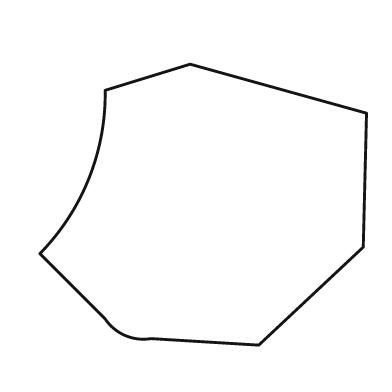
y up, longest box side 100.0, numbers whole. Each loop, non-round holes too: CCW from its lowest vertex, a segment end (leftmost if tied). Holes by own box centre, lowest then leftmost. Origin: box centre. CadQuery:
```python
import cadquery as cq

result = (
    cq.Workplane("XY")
    .moveTo(17.0, -43.0)
    .lineTo(49.0, -13.0)
    .lineTo(50.0, 28.0)
    .lineTo(-4.0, 43.0)
    .lineTo(-30.0, 35.0)
    .threePointArc((-35.0, 8.0), (-50.0, -15.0))
    .lineTo(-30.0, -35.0)
    .threePointArc((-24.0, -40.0), (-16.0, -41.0))
    .close()
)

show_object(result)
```